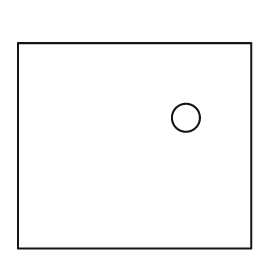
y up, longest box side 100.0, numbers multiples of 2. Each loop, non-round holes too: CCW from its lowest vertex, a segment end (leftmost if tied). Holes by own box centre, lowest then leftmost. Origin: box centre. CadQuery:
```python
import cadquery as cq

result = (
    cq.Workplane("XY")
    .moveTo(-50.0, -44.0)
    .lineTo(50.0, -44.0)
    .lineTo(50.0, 44.0)
    .lineTo(-50.0, 44.0)
    .close()
    .moveTo(22.0, 12.0)
    .circle(6.0)
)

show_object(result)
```